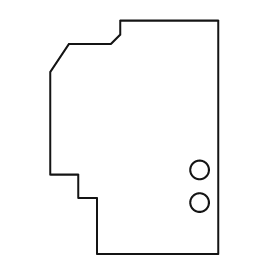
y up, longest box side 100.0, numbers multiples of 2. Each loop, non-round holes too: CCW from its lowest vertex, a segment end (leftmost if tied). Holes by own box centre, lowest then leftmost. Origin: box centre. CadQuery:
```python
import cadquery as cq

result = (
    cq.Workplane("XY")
    .moveTo(-16.0, -50.0)
    .lineTo(36.0, -50.0)
    .lineTo(36.0, 50.0)
    .lineTo(-6.0, 50.0)
    .lineTo(-6.0, 44.0)
    .lineTo(-10.0, 40.0)
    .lineTo(-28.0, 40.0)
    .lineTo(-36.0, 28.0)
    .lineTo(-36.0, -16.0)
    .lineTo(-24.0, -16.0)
    .lineTo(-24.0, -26.0)
    .lineTo(-16.0, -26.0)
    .close()
    .moveTo(28.0, -28.0)
    .circle(4.0)
    .moveTo(28.0, -14.0)
    .circle(4.0)
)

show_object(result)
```